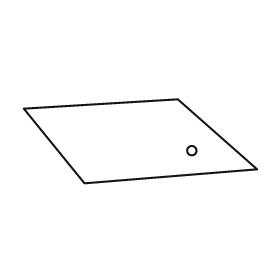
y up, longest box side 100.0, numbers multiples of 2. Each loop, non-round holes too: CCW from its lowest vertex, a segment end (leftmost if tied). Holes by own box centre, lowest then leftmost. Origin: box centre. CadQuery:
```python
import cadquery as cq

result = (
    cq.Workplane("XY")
    .moveTo(-24.0, -18.0)
    .lineTo(50.0, -12.0)
    .lineTo(16.0, 18.0)
    .lineTo(-50.0, 14.0)
    .close()
    .moveTo(22.0, -4.0)
    .circle(2.0)
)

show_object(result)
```